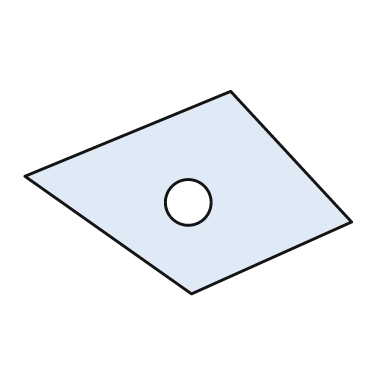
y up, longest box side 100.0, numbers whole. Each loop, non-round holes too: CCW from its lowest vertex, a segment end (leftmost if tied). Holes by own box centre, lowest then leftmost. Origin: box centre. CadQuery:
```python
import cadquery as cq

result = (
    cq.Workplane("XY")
    .moveTo(1.0, -31.0)
    .lineTo(50.0, -9.0)
    .lineTo(13.0, 31.0)
    .lineTo(-50.0, 5.0)
    .close()
    .moveTo(0.0, -3.0)
    .circle(7.0)
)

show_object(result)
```